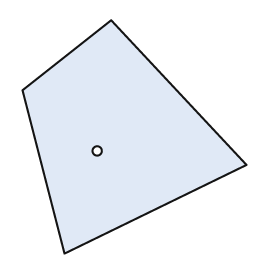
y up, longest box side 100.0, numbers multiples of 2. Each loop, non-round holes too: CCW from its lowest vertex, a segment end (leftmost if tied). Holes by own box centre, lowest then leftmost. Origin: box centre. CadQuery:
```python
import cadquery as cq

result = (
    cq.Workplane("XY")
    .moveTo(-30.0, -50.0)
    .lineTo(48.0, -12.0)
    .lineTo(-10.0, 50.0)
    .lineTo(-48.0, 20.0)
    .close()
    .moveTo(-16.0, -6.0)
    .circle(2.0)
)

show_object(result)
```